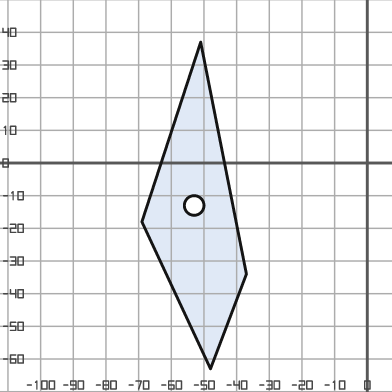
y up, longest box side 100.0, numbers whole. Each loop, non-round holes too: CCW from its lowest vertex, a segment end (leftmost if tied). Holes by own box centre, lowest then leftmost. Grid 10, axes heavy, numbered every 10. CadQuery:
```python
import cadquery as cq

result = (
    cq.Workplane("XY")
    .moveTo(-48.0, -63.0)
    .lineTo(-37.0, -34.0)
    .lineTo(-51.0, 37.0)
    .lineTo(-69.0, -18.0)
    .close()
    .moveTo(-53.0, -13.0)
    .circle(3.0)
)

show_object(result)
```